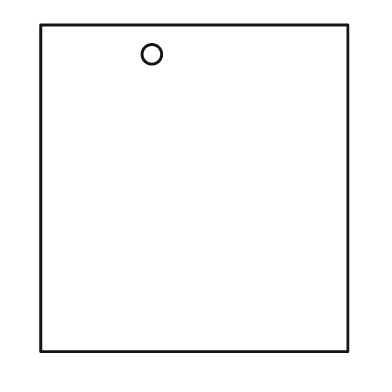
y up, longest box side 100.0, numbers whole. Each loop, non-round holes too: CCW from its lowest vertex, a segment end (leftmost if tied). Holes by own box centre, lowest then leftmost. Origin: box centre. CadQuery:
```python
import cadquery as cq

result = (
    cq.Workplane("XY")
    .moveTo(-47.0, -50.0)
    .lineTo(47.0, -50.0)
    .lineTo(47.0, 50.0)
    .lineTo(-47.0, 50.0)
    .close()
    .moveTo(-13.0, 41.0)
    .circle(3.0)
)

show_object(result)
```